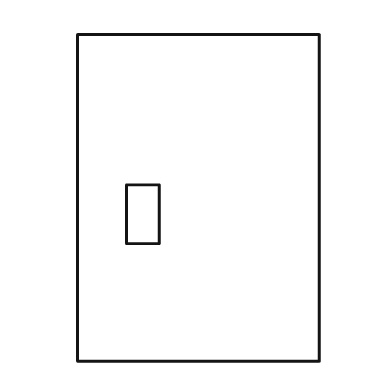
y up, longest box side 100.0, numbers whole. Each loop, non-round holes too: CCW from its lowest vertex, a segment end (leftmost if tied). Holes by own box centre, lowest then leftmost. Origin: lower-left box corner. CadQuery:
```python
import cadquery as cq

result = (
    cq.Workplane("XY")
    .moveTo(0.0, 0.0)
    .lineTo(74.0, 0.0)
    .lineTo(74.0, 100.0)
    .lineTo(0.0, 100.0)
    .close()
    .moveTo(15.0, 36.0)
    .lineTo(25.0, 36.0)
    .lineTo(25.0, 54.0)
    .lineTo(15.0, 54.0)
    .close()
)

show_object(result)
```